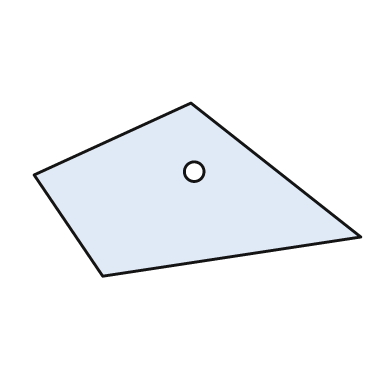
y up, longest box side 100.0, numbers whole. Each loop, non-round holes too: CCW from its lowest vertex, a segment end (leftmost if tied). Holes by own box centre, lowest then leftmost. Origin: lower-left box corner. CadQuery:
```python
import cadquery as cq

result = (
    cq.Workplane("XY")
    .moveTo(21.0, 0.0)
    .lineTo(100.0, 12.0)
    .lineTo(48.0, 53.0)
    .lineTo(0.0, 31.0)
    .close()
    .moveTo(49.0, 32.0)
    .circle(3.0)
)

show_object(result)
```